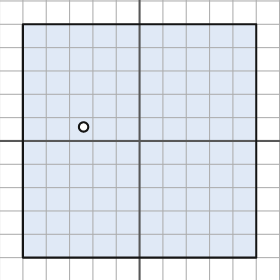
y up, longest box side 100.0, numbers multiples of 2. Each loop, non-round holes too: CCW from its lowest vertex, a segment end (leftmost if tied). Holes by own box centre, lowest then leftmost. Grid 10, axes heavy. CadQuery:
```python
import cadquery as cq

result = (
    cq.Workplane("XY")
    .moveTo(-50.0, -50.0)
    .lineTo(50.0, -50.0)
    .lineTo(50.0, 50.0)
    .lineTo(-50.0, 50.0)
    .close()
    .moveTo(-24.0, 6.0)
    .circle(2.0)
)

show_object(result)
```